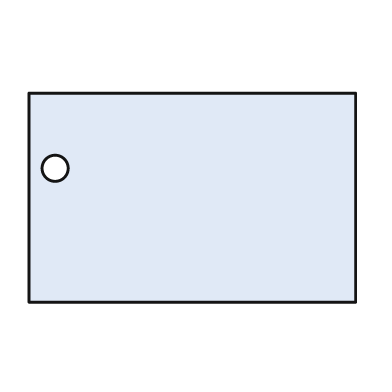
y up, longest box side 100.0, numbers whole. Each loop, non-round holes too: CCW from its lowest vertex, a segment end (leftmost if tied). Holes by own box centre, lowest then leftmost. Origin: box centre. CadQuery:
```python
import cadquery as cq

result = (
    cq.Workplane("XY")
    .moveTo(-50.0, -32.0)
    .lineTo(50.0, -32.0)
    .lineTo(50.0, 32.0)
    .lineTo(-50.0, 32.0)
    .close()
    .moveTo(-42.0, 9.0)
    .circle(4.0)
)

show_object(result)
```